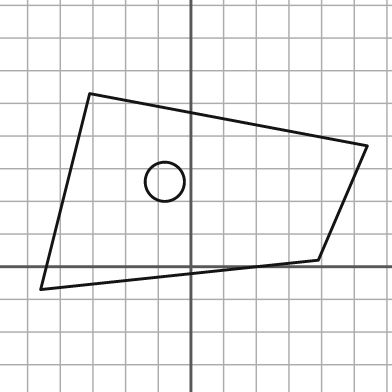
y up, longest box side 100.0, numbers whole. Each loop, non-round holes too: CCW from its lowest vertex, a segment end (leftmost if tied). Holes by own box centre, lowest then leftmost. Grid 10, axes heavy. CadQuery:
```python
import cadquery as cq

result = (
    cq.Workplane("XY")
    .moveTo(-46.0, -7.0)
    .lineTo(39.0, 2.0)
    .lineTo(54.0, 37.0)
    .lineTo(-31.0, 53.0)
    .close()
    .moveTo(-8.0, 26.0)
    .circle(6.0)
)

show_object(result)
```